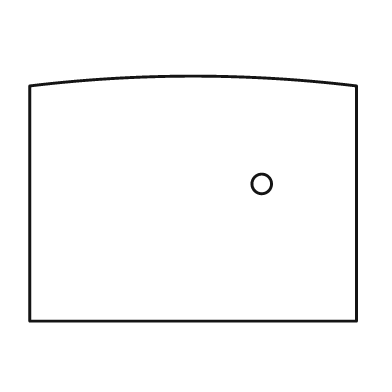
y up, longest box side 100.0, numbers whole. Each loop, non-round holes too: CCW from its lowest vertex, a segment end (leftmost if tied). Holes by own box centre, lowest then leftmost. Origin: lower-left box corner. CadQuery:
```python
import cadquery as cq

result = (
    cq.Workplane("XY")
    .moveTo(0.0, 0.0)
    .lineTo(100.0, 0.0)
    .lineTo(100.0, 72.0)
    .threePointArc((50.0, 75.0), (0.0, 72.0))
    .close()
    .moveTo(71.0, 42.0)
    .circle(3.0)
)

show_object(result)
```